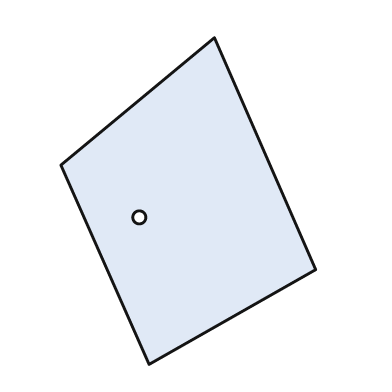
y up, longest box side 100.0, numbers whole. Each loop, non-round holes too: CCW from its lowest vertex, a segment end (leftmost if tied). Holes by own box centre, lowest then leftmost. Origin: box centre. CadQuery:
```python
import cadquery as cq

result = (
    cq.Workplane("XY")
    .moveTo(-12.0, -50.0)
    .lineTo(39.0, -21.0)
    .lineTo(8.0, 50.0)
    .lineTo(-39.0, 11.0)
    .close()
    .moveTo(-15.0, -5.0)
    .circle(2.0)
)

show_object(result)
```